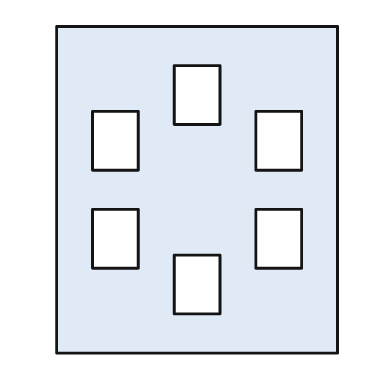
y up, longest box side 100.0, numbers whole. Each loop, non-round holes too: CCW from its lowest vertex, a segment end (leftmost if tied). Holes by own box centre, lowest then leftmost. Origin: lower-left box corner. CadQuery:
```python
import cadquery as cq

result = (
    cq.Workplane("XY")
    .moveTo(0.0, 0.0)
    .lineTo(86.0, 0.0)
    .lineTo(86.0, 100.0)
    .lineTo(0.0, 100.0)
    .close()
    .moveTo(36.0, 12.0)
    .lineTo(50.0, 12.0)
    .lineTo(50.0, 30.0)
    .lineTo(36.0, 30.0)
    .close()
    .moveTo(11.0, 26.0)
    .lineTo(25.0, 26.0)
    .lineTo(25.0, 44.0)
    .lineTo(11.0, 44.0)
    .close()
    .moveTo(61.0, 26.0)
    .lineTo(75.0, 26.0)
    .lineTo(75.0, 44.0)
    .lineTo(61.0, 44.0)
    .close()
    .moveTo(11.0, 56.0)
    .lineTo(25.0, 56.0)
    .lineTo(25.0, 74.0)
    .lineTo(11.0, 74.0)
    .close()
    .moveTo(61.0, 56.0)
    .lineTo(75.0, 56.0)
    .lineTo(75.0, 74.0)
    .lineTo(61.0, 74.0)
    .close()
    .moveTo(36.0, 70.0)
    .lineTo(50.0, 70.0)
    .lineTo(50.0, 88.0)
    .lineTo(36.0, 88.0)
    .close()
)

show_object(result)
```